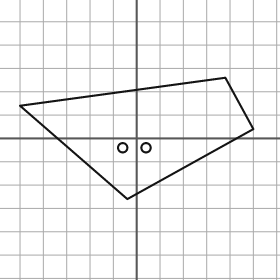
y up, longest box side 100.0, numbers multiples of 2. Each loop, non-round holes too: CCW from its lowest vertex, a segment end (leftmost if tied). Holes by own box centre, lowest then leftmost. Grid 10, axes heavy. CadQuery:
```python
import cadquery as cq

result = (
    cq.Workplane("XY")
    .moveTo(-4.0, -26.0)
    .lineTo(50.0, 4.0)
    .lineTo(38.0, 26.0)
    .lineTo(-50.0, 14.0)
    .close()
    .moveTo(-6.0, -4.0)
    .circle(2.0)
    .moveTo(4.0, -4.0)
    .circle(2.0)
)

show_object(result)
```